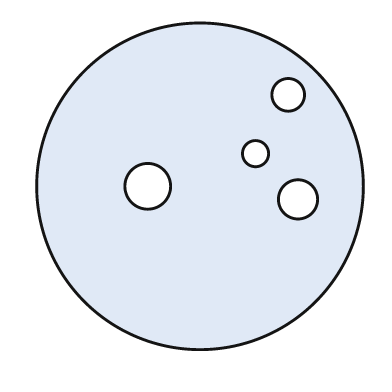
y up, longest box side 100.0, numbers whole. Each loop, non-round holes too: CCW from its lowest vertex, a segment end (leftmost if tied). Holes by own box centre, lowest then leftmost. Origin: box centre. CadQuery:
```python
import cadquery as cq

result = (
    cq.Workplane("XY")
    .moveTo(0.0, 0.0)
    .circle(50.0)
    .moveTo(30.0, -4.0)
    .circle(6.0)
    .moveTo(-16.0, 0.0)
    .circle(7.0)
    .moveTo(17.0, 10.0)
    .circle(4.0)
    .moveTo(27.0, 28.0)
    .circle(5.0)
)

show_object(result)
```